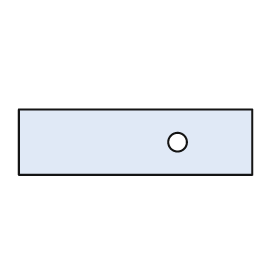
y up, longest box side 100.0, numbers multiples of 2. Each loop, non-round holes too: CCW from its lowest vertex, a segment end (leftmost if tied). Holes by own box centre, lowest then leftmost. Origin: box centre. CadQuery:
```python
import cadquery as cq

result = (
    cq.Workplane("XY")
    .moveTo(-50.0, -14.0)
    .lineTo(50.0, -14.0)
    .lineTo(50.0, 14.0)
    .lineTo(-50.0, 14.0)
    .close()
    .moveTo(18.0, 0.0)
    .circle(4.0)
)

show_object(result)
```